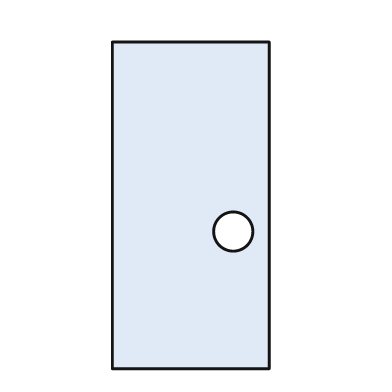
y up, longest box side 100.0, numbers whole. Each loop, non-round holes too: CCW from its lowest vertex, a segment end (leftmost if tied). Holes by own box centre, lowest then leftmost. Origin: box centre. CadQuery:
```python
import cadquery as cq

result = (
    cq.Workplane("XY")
    .moveTo(-24.0, -50.0)
    .lineTo(24.0, -50.0)
    .lineTo(24.0, 50.0)
    .lineTo(-24.0, 50.0)
    .close()
    .moveTo(13.0, -8.0)
    .circle(6.0)
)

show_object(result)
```